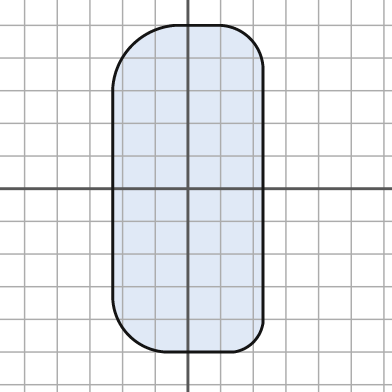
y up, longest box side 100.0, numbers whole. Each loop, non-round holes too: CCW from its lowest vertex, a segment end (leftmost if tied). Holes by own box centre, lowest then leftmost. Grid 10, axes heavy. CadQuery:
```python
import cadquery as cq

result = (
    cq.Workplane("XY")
    .moveTo(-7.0, -50.0)
    .lineTo(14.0, -50.0)
    .threePointArc((20.0, -47.0), (23.0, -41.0))
    .lineTo(23.0, 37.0)
    .threePointArc((19.0, 46.0), (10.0, 50.0))
    .lineTo(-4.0, 50.0)
    .threePointArc((-17.0, 44.0), (-23.0, 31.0))
    .lineTo(-23.0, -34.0)
    .threePointArc((-18.0, -45.0), (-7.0, -50.0))
    .close()
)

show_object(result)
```